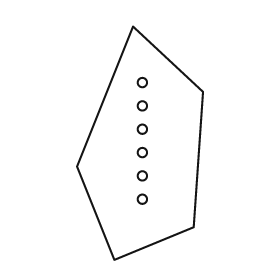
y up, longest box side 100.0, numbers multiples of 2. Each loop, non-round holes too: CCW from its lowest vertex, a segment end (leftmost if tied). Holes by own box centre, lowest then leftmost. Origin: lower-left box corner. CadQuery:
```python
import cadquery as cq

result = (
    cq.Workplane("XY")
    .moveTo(16.0, 0.0)
    .lineTo(50.0, 14.0)
    .lineTo(54.0, 72.0)
    .lineTo(24.0, 100.0)
    .lineTo(0.0, 40.0)
    .close()
    .moveTo(28.0, 26.0)
    .circle(2.0)
    .moveTo(28.0, 36.0)
    .circle(2.0)
    .moveTo(28.0, 46.0)
    .circle(2.0)
    .moveTo(28.0, 56.0)
    .circle(2.0)
    .moveTo(28.0, 66.0)
    .circle(2.0)
    .moveTo(28.0, 76.0)
    .circle(2.0)
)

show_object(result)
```